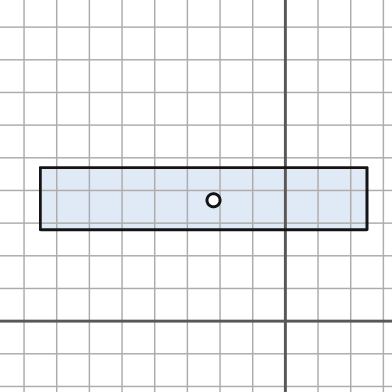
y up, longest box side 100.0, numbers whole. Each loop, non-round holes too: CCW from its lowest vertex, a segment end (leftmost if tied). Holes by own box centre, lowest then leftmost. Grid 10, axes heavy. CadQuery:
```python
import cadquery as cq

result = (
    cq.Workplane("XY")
    .moveTo(-75.0, 28.0)
    .lineTo(25.0, 28.0)
    .lineTo(25.0, 47.0)
    .lineTo(-75.0, 47.0)
    .close()
    .moveTo(-22.0, 37.0)
    .circle(2.0)
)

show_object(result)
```